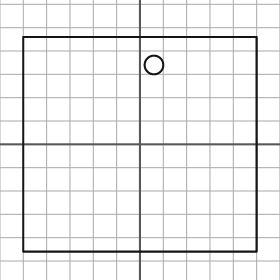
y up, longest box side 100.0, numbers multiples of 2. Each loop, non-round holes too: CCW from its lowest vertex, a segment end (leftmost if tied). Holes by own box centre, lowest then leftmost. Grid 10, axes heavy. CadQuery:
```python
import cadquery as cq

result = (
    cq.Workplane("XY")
    .moveTo(-50.0, -46.0)
    .lineTo(50.0, -46.0)
    .lineTo(50.0, 46.0)
    .lineTo(-50.0, 46.0)
    .close()
    .moveTo(6.0, 34.0)
    .circle(4.0)
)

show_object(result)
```